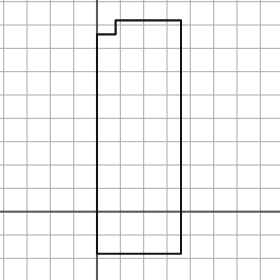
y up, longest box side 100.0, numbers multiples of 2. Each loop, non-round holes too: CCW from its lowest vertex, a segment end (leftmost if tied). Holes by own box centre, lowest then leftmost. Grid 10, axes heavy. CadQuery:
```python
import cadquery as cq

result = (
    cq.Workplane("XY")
    .moveTo(0.0, -18.0)
    .lineTo(36.0, -18.0)
    .lineTo(36.0, 82.0)
    .lineTo(8.0, 82.0)
    .lineTo(8.0, 76.0)
    .lineTo(0.0, 76.0)
    .close()
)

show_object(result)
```